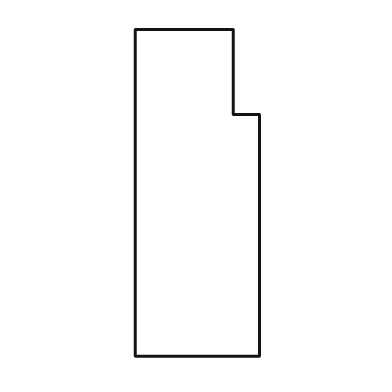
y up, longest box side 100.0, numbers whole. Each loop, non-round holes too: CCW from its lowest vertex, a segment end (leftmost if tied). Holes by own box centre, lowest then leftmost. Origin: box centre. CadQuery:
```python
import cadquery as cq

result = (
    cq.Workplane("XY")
    .moveTo(-19.0, -50.0)
    .lineTo(19.0, -50.0)
    .lineTo(19.0, 24.0)
    .lineTo(11.0, 24.0)
    .lineTo(11.0, 50.0)
    .lineTo(-19.0, 50.0)
    .close()
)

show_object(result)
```